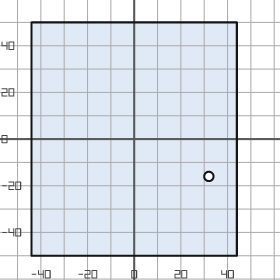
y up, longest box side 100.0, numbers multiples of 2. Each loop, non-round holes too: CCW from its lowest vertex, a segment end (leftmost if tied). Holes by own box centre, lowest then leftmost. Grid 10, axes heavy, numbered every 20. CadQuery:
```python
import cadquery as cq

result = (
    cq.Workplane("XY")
    .moveTo(-44.0, -50.0)
    .lineTo(44.0, -50.0)
    .lineTo(44.0, 50.0)
    .lineTo(-44.0, 50.0)
    .close()
    .moveTo(32.0, -16.0)
    .circle(2.0)
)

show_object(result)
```